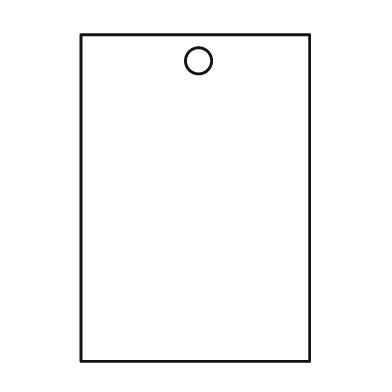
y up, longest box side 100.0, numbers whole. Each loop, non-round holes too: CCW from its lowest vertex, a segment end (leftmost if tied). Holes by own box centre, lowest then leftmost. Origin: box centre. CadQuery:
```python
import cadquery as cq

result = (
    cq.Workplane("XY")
    .moveTo(-35.0, -50.0)
    .lineTo(35.0, -50.0)
    .lineTo(35.0, 50.0)
    .lineTo(-35.0, 50.0)
    .close()
    .moveTo(1.0, 42.0)
    .circle(4.0)
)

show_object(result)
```